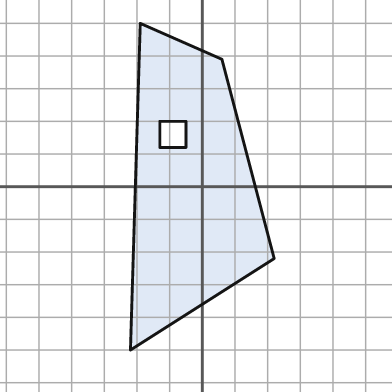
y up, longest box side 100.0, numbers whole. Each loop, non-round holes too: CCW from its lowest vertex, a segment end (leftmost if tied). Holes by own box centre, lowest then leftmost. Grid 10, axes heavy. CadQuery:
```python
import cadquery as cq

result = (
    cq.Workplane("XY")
    .moveTo(-22.0, -50.0)
    .lineTo(22.0, -22.0)
    .lineTo(6.0, 39.0)
    .lineTo(-19.0, 50.0)
    .close()
    .moveTo(-13.0, 12.0)
    .lineTo(-5.0, 12.0)
    .lineTo(-5.0, 20.0)
    .lineTo(-13.0, 20.0)
    .close()
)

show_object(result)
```